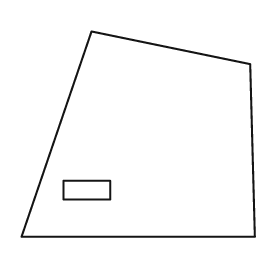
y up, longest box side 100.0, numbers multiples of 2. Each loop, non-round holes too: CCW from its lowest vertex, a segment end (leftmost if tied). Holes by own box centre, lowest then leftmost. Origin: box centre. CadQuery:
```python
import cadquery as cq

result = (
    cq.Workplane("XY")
    .moveTo(-50.0, -44.0)
    .lineTo(50.0, -44.0)
    .lineTo(48.0, 30.0)
    .lineTo(-20.0, 44.0)
    .close()
    .moveTo(-32.0, -28.0)
    .lineTo(-12.0, -28.0)
    .lineTo(-12.0, -20.0)
    .lineTo(-32.0, -20.0)
    .close()
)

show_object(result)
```